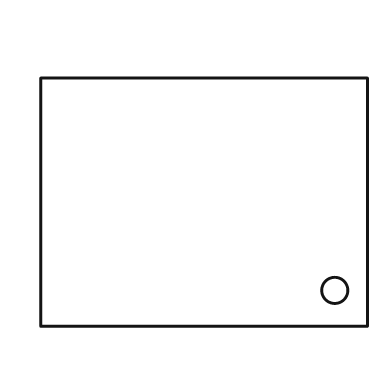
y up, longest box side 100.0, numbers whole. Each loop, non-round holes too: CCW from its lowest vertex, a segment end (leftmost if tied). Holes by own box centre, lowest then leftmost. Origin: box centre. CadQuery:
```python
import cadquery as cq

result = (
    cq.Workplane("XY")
    .moveTo(-50.0, -38.0)
    .lineTo(50.0, -38.0)
    .lineTo(50.0, 38.0)
    .lineTo(-50.0, 38.0)
    .close()
    .moveTo(40.0, -27.0)
    .circle(4.0)
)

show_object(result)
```